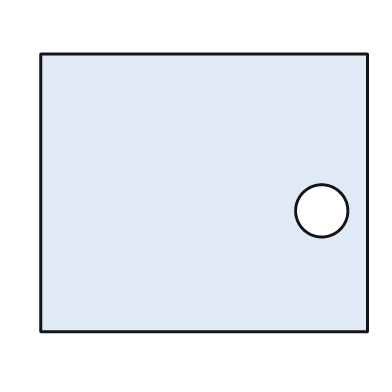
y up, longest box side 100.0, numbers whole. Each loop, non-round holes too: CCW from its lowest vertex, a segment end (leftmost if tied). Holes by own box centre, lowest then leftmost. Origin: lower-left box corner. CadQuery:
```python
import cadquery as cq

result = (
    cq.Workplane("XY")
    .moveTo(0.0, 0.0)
    .lineTo(100.0, 0.0)
    .lineTo(100.0, 85.0)
    .lineTo(0.0, 85.0)
    .close()
    .moveTo(86.0, 37.0)
    .circle(8.0)
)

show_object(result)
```